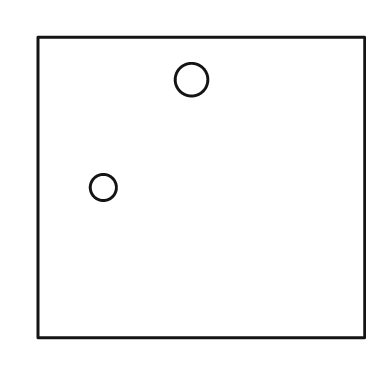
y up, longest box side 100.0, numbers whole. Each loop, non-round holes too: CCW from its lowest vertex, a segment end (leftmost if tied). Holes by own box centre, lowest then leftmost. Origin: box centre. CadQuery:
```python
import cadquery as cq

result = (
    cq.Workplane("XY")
    .moveTo(-50.0, -46.0)
    .lineTo(50.0, -46.0)
    .lineTo(50.0, 46.0)
    .lineTo(-50.0, 46.0)
    .close()
    .moveTo(-30.0, 0.0)
    .circle(4.0)
    .moveTo(-3.0, 33.0)
    .circle(5.0)
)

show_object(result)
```